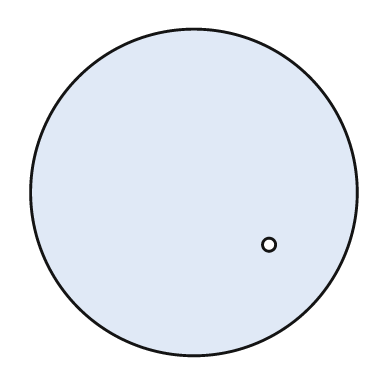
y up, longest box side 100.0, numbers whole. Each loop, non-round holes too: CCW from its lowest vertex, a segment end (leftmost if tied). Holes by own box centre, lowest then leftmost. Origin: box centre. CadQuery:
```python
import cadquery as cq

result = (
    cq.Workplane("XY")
    .moveTo(0.0, 0.0)
    .circle(50.0)
    .moveTo(23.0, -16.0)
    .circle(2.0)
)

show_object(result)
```